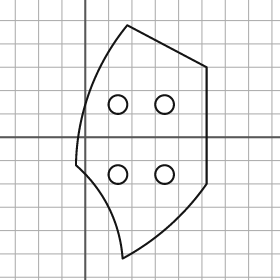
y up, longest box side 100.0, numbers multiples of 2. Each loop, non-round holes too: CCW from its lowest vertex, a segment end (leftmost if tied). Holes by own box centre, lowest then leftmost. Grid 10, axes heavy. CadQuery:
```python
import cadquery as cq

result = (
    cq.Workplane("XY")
    .moveTo(16.0, -52.0)
    .threePointArc((36.0, -38.0), (52.0, -20.0))
    .lineTo(52.0, 30.0)
    .lineTo(18.0, 48.0)
    .threePointArc((2.0, 20.0), (-4.0, -12.0))
    .threePointArc((10.0, -30.0), (16.0, -52.0))
    .close()
    .moveTo(14.0, -16.0)
    .circle(4.0)
    .moveTo(34.0, -16.0)
    .circle(4.0)
    .moveTo(14.0, 14.0)
    .circle(4.0)
    .moveTo(34.0, 14.0)
    .circle(4.0)
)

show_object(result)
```